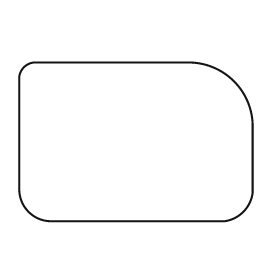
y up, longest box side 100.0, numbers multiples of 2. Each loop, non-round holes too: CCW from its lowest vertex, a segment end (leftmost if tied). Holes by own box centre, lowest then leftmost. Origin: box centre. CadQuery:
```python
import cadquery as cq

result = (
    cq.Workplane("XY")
    .moveTo(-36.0, -34.0)
    .lineTo(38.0, -34.0)
    .threePointArc((46.0, -30.0), (50.0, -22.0))
    .lineTo(50.0, 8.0)
    .threePointArc((42.0, 26.0), (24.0, 34.0))
    .lineTo(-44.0, 34.0)
    .threePointArc((-48.0, 32.0), (-50.0, 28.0))
    .lineTo(-50.0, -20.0)
    .threePointArc((-46.0, -30.0), (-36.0, -34.0))
    .close()
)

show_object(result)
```